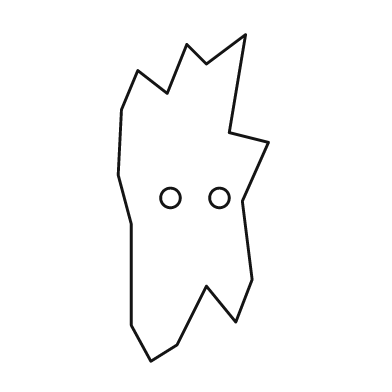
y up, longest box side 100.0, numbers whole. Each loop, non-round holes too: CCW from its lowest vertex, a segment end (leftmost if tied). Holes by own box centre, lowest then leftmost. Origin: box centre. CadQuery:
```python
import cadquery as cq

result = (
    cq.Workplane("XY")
    .moveTo(-13.0, -50.0)
    .lineTo(-5.0, -45.0)
    .lineTo(4.0, -27.0)
    .lineTo(13.0, -38.0)
    .lineTo(18.0, -25.0)
    .lineTo(15.0, -1.0)
    .lineTo(23.0, 17.0)
    .lineTo(11.0, 20.0)
    .lineTo(16.0, 50.0)
    .lineTo(4.0, 41.0)
    .lineTo(-2.0, 47.0)
    .lineTo(-8.0, 32.0)
    .lineTo(-17.0, 39.0)
    .lineTo(-22.0, 27.0)
    .lineTo(-23.0, 7.0)
    .lineTo(-19.0, -8.0)
    .lineTo(-19.0, -39.0)
    .close()
    .moveTo(-7.0, 0.0)
    .circle(3.0)
    .moveTo(8.0, 0.0)
    .circle(3.0)
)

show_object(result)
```